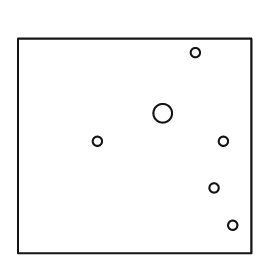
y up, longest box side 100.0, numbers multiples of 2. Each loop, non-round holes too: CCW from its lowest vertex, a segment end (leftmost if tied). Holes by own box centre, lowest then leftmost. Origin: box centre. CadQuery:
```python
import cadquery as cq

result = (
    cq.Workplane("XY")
    .moveTo(-50.0, -46.0)
    .lineTo(50.0, -46.0)
    .lineTo(50.0, 46.0)
    .lineTo(-50.0, 46.0)
    .close()
    .moveTo(42.0, -34.0)
    .circle(2.0)
    .moveTo(34.0, -18.0)
    .circle(2.0)
    .moveTo(-16.0, 2.0)
    .circle(2.0)
    .moveTo(38.0, 2.0)
    .circle(2.0)
    .moveTo(12.0, 14.0)
    .circle(4.0)
    .moveTo(26.0, 40.0)
    .circle(2.0)
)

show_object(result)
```